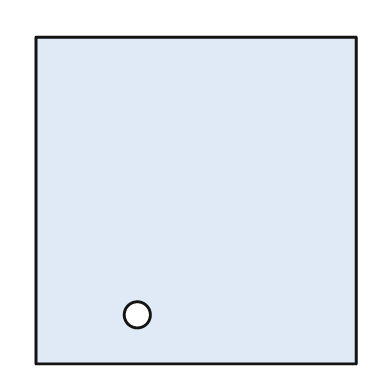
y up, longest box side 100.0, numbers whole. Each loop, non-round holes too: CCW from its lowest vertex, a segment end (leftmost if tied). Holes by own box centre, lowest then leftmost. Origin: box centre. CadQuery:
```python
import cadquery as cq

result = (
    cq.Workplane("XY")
    .moveTo(-49.0, -50.0)
    .lineTo(49.0, -50.0)
    .lineTo(49.0, 50.0)
    .lineTo(-49.0, 50.0)
    .close()
    .moveTo(-18.0, -35.0)
    .circle(4.0)
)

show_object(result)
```